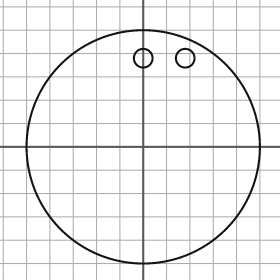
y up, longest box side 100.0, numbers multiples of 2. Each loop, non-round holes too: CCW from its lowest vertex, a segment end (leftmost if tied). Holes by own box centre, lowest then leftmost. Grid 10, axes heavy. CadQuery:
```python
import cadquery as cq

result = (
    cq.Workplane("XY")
    .moveTo(0.0, 0.0)
    .circle(50.0)
    .moveTo(0.0, 38.0)
    .circle(4.0)
    .moveTo(18.0, 38.0)
    .circle(4.0)
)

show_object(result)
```